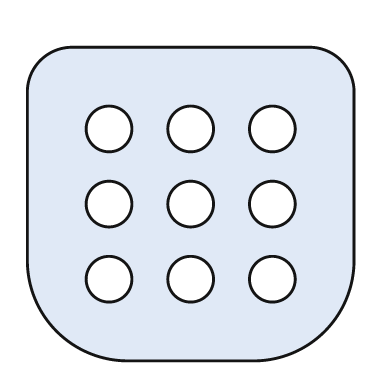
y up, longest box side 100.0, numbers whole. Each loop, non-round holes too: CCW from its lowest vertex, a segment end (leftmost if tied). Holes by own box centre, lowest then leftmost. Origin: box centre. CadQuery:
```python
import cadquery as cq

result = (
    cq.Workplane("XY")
    .moveTo(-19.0, -48.0)
    .lineTo(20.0, -48.0)
    .threePointArc((41.0, -39.0), (50.0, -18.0))
    .lineTo(50.0, 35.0)
    .threePointArc((46.0, 44.0), (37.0, 48.0))
    .lineTo(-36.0, 48.0)
    .threePointArc((-46.0, 44.0), (-50.0, 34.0))
    .lineTo(-50.0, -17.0)
    .threePointArc((-41.0, -39.0), (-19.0, -48.0))
    .close()
    .moveTo(-25.0, -23.0)
    .circle(7.0)
    .moveTo(0.0, -23.0)
    .circle(7.0)
    .moveTo(25.0, -23.0)
    .circle(7.0)
    .moveTo(-25.0, 0.0)
    .circle(7.0)
    .moveTo(0.0, 0.0)
    .circle(7.0)
    .moveTo(25.0, 0.0)
    .circle(7.0)
    .moveTo(-25.0, 23.0)
    .circle(7.0)
    .moveTo(0.0, 23.0)
    .circle(7.0)
    .moveTo(25.0, 23.0)
    .circle(7.0)
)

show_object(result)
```